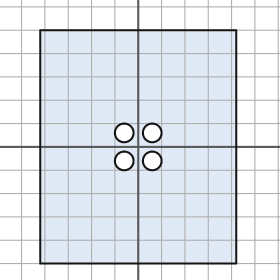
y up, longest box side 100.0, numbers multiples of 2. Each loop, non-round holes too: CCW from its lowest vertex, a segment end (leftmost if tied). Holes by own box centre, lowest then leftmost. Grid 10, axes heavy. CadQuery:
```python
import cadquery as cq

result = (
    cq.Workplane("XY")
    .moveTo(-42.0, -50.0)
    .lineTo(42.0, -50.0)
    .lineTo(42.0, 50.0)
    .lineTo(-42.0, 50.0)
    .close()
    .moveTo(-6.0, -6.0)
    .circle(4.0)
    .moveTo(6.0, -6.0)
    .circle(4.0)
    .moveTo(-6.0, 6.0)
    .circle(4.0)
    .moveTo(6.0, 6.0)
    .circle(4.0)
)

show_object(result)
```